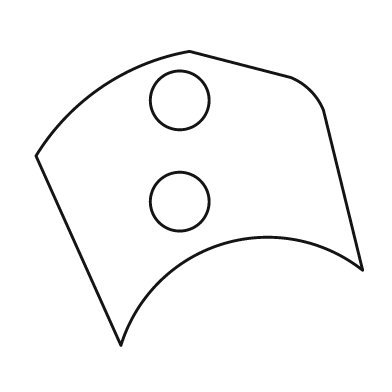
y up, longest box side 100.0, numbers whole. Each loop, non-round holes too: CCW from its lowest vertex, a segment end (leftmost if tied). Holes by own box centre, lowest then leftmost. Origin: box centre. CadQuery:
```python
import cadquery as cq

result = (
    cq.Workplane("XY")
    .moveTo(-24.0, -45.0)
    .threePointArc((7.0, -14.0), (50.0, -22.0))
    .lineTo(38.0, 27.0)
    .threePointArc((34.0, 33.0), (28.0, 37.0))
    .lineTo(-3.0, 45.0)
    .threePointArc((-30.0, 34.0), (-50.0, 13.0))
    .close()
    .moveTo(-6.0, -1.0)
    .circle(9.0)
    .moveTo(-6.0, 30.0)
    .circle(9.0)
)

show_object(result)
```